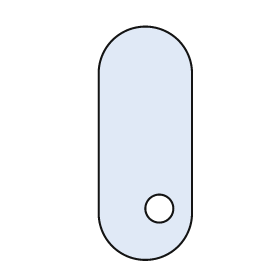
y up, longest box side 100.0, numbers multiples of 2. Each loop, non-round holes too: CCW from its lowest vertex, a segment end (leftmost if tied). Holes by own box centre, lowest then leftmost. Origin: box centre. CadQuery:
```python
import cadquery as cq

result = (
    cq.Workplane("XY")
    .moveTo(-20.0, -30.0)
    .threePointArc((0.0, -50.0), (20.0, -30.0))
    .lineTo(20.0, 30.0)
    .threePointArc((0.0, 50.0), (-20.0, 30.0))
    .close()
    .moveTo(6.0, -28.0)
    .circle(6.0)
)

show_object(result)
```